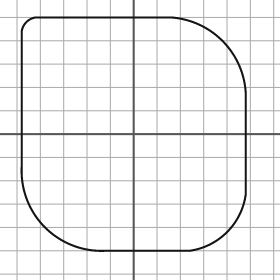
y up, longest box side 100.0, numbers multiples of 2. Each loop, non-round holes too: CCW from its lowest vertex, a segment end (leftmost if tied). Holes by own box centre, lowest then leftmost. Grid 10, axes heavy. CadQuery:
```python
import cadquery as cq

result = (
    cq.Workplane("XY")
    .moveTo(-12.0, -50.0)
    .lineTo(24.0, -50.0)
    .threePointArc((40.0, -42.0), (48.0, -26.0))
    .lineTo(48.0, 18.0)
    .threePointArc((38.0, 40.0), (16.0, 50.0))
    .lineTo(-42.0, 50.0)
    .threePointArc((-46.0, 48.0), (-48.0, 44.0))
    .lineTo(-48.0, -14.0)
    .threePointArc((-38.0, -40.0), (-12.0, -50.0))
    .close()
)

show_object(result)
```